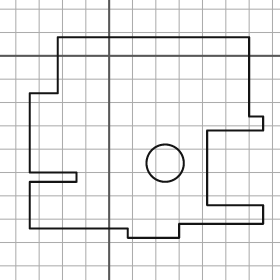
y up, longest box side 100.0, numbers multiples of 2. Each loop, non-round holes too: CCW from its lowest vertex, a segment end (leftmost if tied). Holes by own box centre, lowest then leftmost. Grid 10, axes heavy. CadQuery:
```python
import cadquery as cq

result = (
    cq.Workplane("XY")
    .moveTo(8.0, -78.0)
    .lineTo(30.0, -78.0)
    .lineTo(30.0, -72.0)
    .lineTo(66.0, -72.0)
    .lineTo(66.0, -64.0)
    .lineTo(42.0, -64.0)
    .lineTo(42.0, -32.0)
    .lineTo(66.0, -32.0)
    .lineTo(66.0, -26.0)
    .lineTo(60.0, -26.0)
    .lineTo(60.0, 8.0)
    .lineTo(-22.0, 8.0)
    .lineTo(-22.0, -16.0)
    .lineTo(-34.0, -16.0)
    .lineTo(-34.0, -50.0)
    .lineTo(-14.0, -50.0)
    .lineTo(-14.0, -54.0)
    .lineTo(-34.0, -54.0)
    .lineTo(-34.0, -74.0)
    .lineTo(8.0, -74.0)
    .close()
    .moveTo(24.0, -46.0)
    .circle(8.0)
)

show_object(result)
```